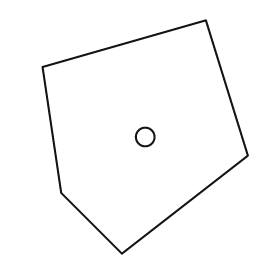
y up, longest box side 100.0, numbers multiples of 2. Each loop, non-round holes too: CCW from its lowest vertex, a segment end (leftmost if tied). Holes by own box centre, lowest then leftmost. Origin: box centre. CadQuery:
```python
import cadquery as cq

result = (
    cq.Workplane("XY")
    .moveTo(-10.0, -50.0)
    .lineTo(44.0, -8.0)
    .lineTo(26.0, 50.0)
    .lineTo(-44.0, 30.0)
    .lineTo(-36.0, -24.0)
    .close()
    .moveTo(0.0, 0.0)
    .circle(4.0)
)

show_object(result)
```